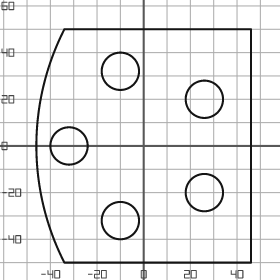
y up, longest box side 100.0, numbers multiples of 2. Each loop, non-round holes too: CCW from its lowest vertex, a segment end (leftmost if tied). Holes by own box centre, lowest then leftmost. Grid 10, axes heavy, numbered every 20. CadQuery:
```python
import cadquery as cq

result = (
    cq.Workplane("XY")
    .moveTo(-34.0, -50.0)
    .lineTo(46.0, -50.0)
    .lineTo(46.0, 50.0)
    .lineTo(-34.0, 50.0)
    .threePointArc((-46.0, 0.0), (-34.0, -50.0))
    .close()
    .moveTo(-10.0, -32.0)
    .circle(8.0)
    .moveTo(26.0, -20.0)
    .circle(8.0)
    .moveTo(-32.0, 0.0)
    .circle(8.0)
    .moveTo(26.0, 20.0)
    .circle(8.0)
    .moveTo(-10.0, 32.0)
    .circle(8.0)
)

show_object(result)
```